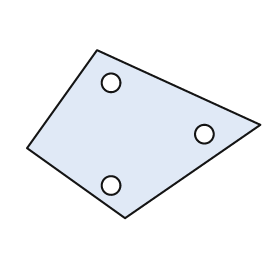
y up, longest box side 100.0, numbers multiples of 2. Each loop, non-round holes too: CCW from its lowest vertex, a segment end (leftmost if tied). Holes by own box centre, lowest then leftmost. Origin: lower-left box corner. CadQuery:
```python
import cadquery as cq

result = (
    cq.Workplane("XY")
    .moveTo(42.0, 0.0)
    .lineTo(100.0, 40.0)
    .lineTo(30.0, 72.0)
    .lineTo(0.0, 30.0)
    .close()
    .moveTo(36.0, 14.0)
    .circle(4.0)
    .moveTo(76.0, 36.0)
    .circle(4.0)
    .moveTo(36.0, 58.0)
    .circle(4.0)
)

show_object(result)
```